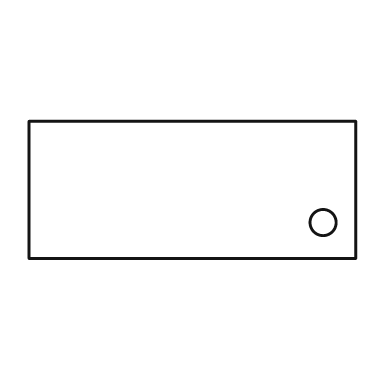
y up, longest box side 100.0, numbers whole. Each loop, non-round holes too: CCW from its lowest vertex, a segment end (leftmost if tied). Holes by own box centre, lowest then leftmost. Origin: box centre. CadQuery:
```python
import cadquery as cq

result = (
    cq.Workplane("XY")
    .moveTo(-50.0, -21.0)
    .lineTo(50.0, -21.0)
    .lineTo(50.0, 21.0)
    .lineTo(-50.0, 21.0)
    .close()
    .moveTo(40.0, -10.0)
    .circle(4.0)
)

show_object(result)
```